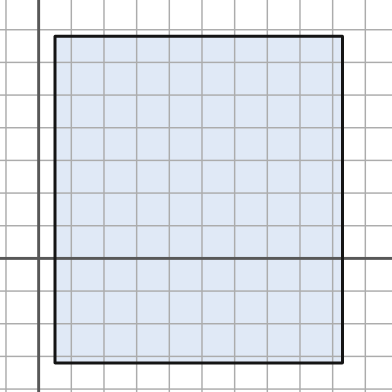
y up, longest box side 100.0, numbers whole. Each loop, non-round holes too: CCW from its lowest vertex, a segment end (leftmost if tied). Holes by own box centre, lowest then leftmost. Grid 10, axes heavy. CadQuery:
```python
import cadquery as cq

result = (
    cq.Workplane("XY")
    .moveTo(5.0, -32.0)
    .lineTo(93.0, -32.0)
    .lineTo(93.0, 68.0)
    .lineTo(5.0, 68.0)
    .close()
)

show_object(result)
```